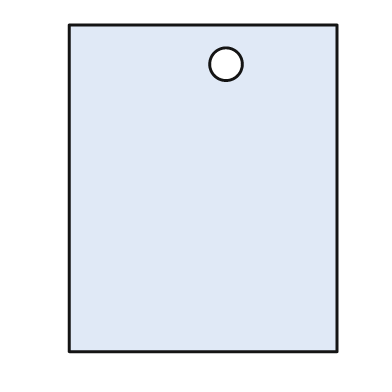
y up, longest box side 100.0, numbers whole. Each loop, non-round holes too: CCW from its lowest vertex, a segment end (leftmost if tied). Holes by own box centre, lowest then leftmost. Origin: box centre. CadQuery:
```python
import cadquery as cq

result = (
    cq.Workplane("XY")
    .moveTo(-41.0, -50.0)
    .lineTo(41.0, -50.0)
    .lineTo(41.0, 50.0)
    .lineTo(-41.0, 50.0)
    .close()
    .moveTo(7.0, 38.0)
    .circle(5.0)
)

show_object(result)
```